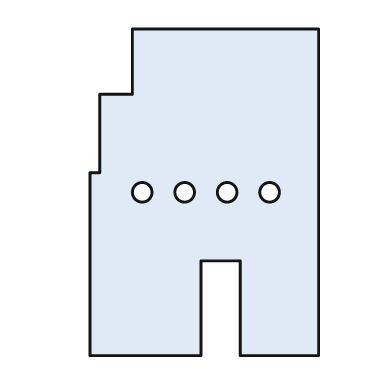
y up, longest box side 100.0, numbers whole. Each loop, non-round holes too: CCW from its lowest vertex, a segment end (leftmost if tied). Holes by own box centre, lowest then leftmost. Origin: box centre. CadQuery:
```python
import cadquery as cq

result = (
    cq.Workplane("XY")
    .moveTo(-35.0, -50.0)
    .lineTo(-1.0, -50.0)
    .lineTo(-1.0, -21.0)
    .lineTo(11.0, -21.0)
    .lineTo(11.0, -50.0)
    .lineTo(35.0, -50.0)
    .lineTo(35.0, 50.0)
    .lineTo(-22.0, 50.0)
    .lineTo(-22.0, 30.0)
    .lineTo(-32.0, 30.0)
    .lineTo(-32.0, 6.0)
    .lineTo(-35.0, 6.0)
    .close()
    .moveTo(-19.0, 0.0)
    .circle(3.0)
    .moveTo(-6.0, 0.0)
    .circle(3.0)
    .moveTo(7.0, 0.0)
    .circle(3.0)
    .moveTo(20.0, 0.0)
    .circle(3.0)
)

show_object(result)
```